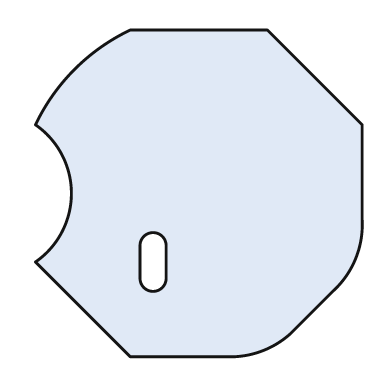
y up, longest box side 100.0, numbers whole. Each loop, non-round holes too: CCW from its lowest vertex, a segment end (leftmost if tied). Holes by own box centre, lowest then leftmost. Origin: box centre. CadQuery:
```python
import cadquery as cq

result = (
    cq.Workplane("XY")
    .moveTo(-21.0, -50.0)
    .lineTo(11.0, -50.0)
    .threePointArc((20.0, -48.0), (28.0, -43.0))
    .lineTo(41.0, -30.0)
    .threePointArc((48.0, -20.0), (50.0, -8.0))
    .lineTo(50.0, 21.0)
    .lineTo(21.0, 50.0)
    .lineTo(-21.0, 50.0)
    .threePointArc((-38.0, 38.0), (-50.0, 21.0))
    .threePointArc((-39.0, 0.0), (-50.0, -21.0))
    .close()
    .moveTo(-18.0, -26.0)
    .threePointArc((-14.0, -30.0), (-10.0, -26.0))
    .lineTo(-10.0, -16.0)
    .threePointArc((-14.0, -12.0), (-18.0, -16.0))
    .close()
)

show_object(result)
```